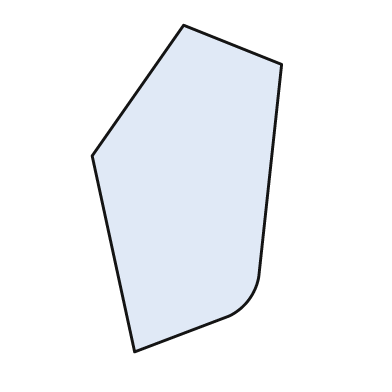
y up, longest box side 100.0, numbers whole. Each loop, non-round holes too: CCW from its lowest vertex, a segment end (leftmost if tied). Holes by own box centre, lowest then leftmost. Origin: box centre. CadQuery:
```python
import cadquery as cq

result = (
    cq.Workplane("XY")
    .moveTo(-16.0, -50.0)
    .lineTo(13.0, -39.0)
    .threePointArc((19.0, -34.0), (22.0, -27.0))
    .lineTo(29.0, 38.0)
    .lineTo(-1.0, 50.0)
    .lineTo(-29.0, 10.0)
    .close()
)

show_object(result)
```